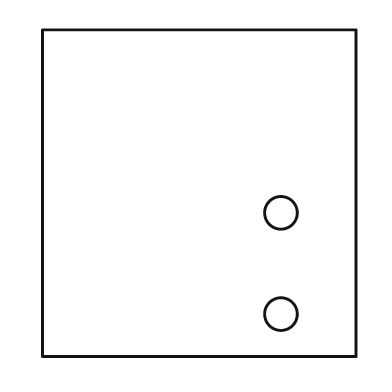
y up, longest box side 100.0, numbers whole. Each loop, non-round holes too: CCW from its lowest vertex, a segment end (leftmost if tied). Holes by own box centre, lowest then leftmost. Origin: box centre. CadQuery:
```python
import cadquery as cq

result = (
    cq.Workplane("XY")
    .moveTo(-48.0, -50.0)
    .lineTo(48.0, -50.0)
    .lineTo(48.0, 50.0)
    .lineTo(-48.0, 50.0)
    .close()
    .moveTo(25.0, -37.0)
    .circle(5.0)
    .moveTo(25.0, -6.0)
    .circle(5.0)
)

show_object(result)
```